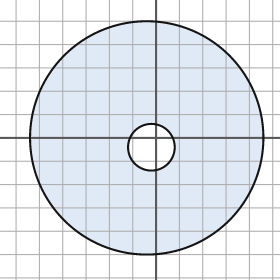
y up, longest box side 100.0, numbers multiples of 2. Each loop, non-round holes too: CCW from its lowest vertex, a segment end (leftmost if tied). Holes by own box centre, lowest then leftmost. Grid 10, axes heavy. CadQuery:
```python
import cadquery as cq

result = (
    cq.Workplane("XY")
    .moveTo(-4.0, 0.0)
    .circle(50.0)
    .moveTo(-2.0, -4.0)
    .circle(10.0)
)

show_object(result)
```